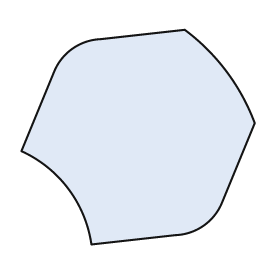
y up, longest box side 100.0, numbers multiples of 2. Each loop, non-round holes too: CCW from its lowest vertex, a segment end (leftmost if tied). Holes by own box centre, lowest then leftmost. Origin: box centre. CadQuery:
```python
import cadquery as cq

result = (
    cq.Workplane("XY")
    .moveTo(-20.0, -46.0)
    .lineTo(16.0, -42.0)
    .threePointArc((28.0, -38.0), (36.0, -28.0))
    .lineTo(50.0, 6.0)
    .threePointArc((38.0, 28.0), (20.0, 46.0))
    .lineTo(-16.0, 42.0)
    .threePointArc((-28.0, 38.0), (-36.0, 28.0))
    .lineTo(-50.0, -6.0)
    .threePointArc((-30.0, -22.0), (-20.0, -46.0))
    .close()
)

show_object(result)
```